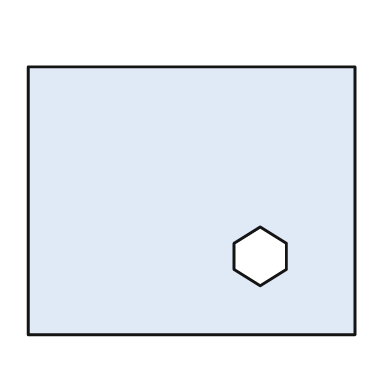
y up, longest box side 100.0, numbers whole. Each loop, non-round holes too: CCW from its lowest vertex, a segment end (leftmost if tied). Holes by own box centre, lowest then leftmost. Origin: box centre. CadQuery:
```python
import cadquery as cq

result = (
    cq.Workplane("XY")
    .moveTo(-50.0, -41.0)
    .lineTo(50.0, -41.0)
    .lineTo(50.0, 41.0)
    .lineTo(-50.0, 41.0)
    .close()
    .moveTo(21.0, -26.0)
    .lineTo(29.0, -21.0)
    .lineTo(29.0, -13.0)
    .lineTo(21.0, -8.0)
    .lineTo(13.0, -13.0)
    .lineTo(13.0, -21.0)
    .close()
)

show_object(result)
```